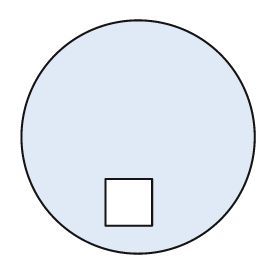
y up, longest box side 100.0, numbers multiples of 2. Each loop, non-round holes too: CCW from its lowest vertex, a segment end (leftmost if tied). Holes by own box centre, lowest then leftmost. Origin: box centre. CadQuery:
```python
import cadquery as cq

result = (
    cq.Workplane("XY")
    .moveTo(0.0, 0.0)
    .circle(50.0)
    .moveTo(-14.0, -38.0)
    .lineTo(6.0, -38.0)
    .lineTo(6.0, -18.0)
    .lineTo(-14.0, -18.0)
    .close()
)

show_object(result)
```